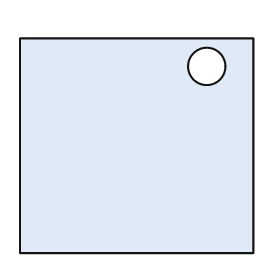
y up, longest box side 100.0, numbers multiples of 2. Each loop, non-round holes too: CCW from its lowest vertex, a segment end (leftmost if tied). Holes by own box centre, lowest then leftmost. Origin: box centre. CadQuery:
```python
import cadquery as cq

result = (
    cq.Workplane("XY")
    .moveTo(-50.0, -46.0)
    .lineTo(50.0, -46.0)
    .lineTo(50.0, 46.0)
    .lineTo(-50.0, 46.0)
    .close()
    .moveTo(30.0, 34.0)
    .circle(8.0)
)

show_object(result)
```